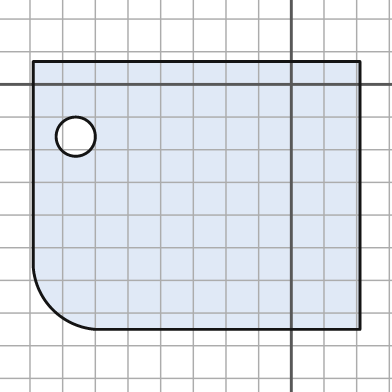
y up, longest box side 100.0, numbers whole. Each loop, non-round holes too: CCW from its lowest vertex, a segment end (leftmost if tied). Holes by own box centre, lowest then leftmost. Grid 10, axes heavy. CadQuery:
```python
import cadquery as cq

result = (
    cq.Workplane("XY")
    .moveTo(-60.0, -75.0)
    .lineTo(21.0, -75.0)
    .lineTo(21.0, 7.0)
    .lineTo(-79.0, 7.0)
    .lineTo(-79.0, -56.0)
    .threePointArc((-73.0, -69.0), (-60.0, -75.0))
    .close()
    .moveTo(-66.0, -16.0)
    .circle(6.0)
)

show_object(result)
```